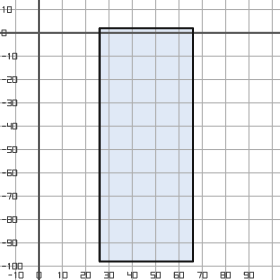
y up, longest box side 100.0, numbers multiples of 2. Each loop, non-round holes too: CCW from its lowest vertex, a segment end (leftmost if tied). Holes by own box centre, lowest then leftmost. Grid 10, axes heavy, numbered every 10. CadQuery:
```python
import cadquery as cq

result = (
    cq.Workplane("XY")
    .moveTo(26.0, -98.0)
    .lineTo(66.0, -98.0)
    .lineTo(66.0, 2.0)
    .lineTo(26.0, 2.0)
    .close()
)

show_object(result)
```